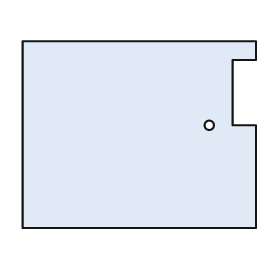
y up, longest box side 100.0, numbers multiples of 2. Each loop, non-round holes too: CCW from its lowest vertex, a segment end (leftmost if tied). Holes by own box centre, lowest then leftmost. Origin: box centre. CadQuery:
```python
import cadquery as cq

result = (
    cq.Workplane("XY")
    .moveTo(-50.0, -40.0)
    .lineTo(50.0, -40.0)
    .lineTo(50.0, 4.0)
    .lineTo(40.0, 4.0)
    .lineTo(40.0, 32.0)
    .lineTo(50.0, 32.0)
    .lineTo(50.0, 40.0)
    .lineTo(-50.0, 40.0)
    .close()
    .moveTo(30.0, 4.0)
    .circle(2.0)
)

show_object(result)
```